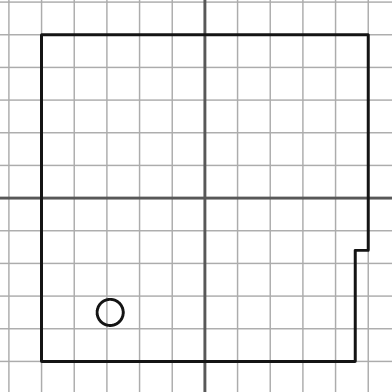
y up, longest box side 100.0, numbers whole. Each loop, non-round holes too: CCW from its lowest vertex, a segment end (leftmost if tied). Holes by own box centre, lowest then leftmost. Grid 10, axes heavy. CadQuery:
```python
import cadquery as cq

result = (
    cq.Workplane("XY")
    .moveTo(-50.0, -50.0)
    .lineTo(46.0, -50.0)
    .lineTo(46.0, -16.0)
    .lineTo(50.0, -16.0)
    .lineTo(50.0, 50.0)
    .lineTo(-50.0, 50.0)
    .close()
    .moveTo(-29.0, -35.0)
    .circle(4.0)
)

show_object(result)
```